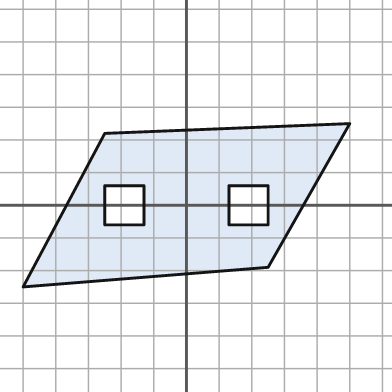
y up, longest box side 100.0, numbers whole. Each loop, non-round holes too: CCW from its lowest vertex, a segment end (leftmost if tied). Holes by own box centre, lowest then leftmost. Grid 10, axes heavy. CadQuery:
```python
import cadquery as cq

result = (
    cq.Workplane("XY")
    .moveTo(-50.0, -25.0)
    .lineTo(25.0, -19.0)
    .lineTo(50.0, 25.0)
    .lineTo(-25.0, 22.0)
    .close()
    .moveTo(-25.0, -6.0)
    .lineTo(-13.0, -6.0)
    .lineTo(-13.0, 6.0)
    .lineTo(-25.0, 6.0)
    .close()
    .moveTo(13.0, -6.0)
    .lineTo(25.0, -6.0)
    .lineTo(25.0, 6.0)
    .lineTo(13.0, 6.0)
    .close()
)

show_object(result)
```